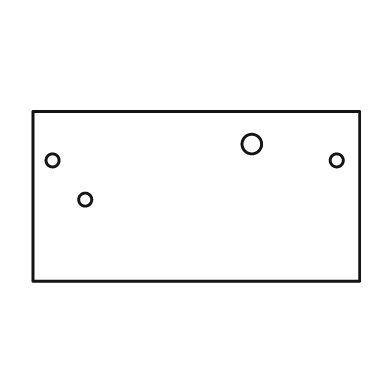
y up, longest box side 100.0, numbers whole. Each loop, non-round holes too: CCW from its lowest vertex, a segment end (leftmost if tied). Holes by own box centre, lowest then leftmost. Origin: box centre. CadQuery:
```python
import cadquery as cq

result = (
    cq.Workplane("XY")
    .moveTo(-50.0, -26.0)
    .lineTo(50.0, -26.0)
    .lineTo(50.0, 26.0)
    .lineTo(-50.0, 26.0)
    .close()
    .moveTo(-34.0, -1.0)
    .circle(2.0)
    .moveTo(-44.0, 11.0)
    .circle(2.0)
    .moveTo(43.0, 11.0)
    .circle(2.0)
    .moveTo(17.0, 16.0)
    .circle(3.0)
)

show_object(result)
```